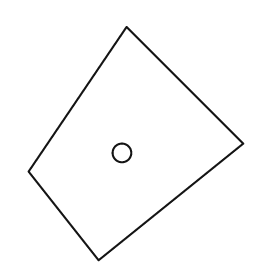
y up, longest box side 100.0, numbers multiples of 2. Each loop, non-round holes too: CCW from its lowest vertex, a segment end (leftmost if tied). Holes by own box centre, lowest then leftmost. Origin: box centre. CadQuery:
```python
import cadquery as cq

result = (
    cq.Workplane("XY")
    .moveTo(-16.0, -50.0)
    .lineTo(46.0, 0.0)
    .lineTo(-4.0, 50.0)
    .lineTo(-46.0, -12.0)
    .close()
    .moveTo(-6.0, -4.0)
    .circle(4.0)
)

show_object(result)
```